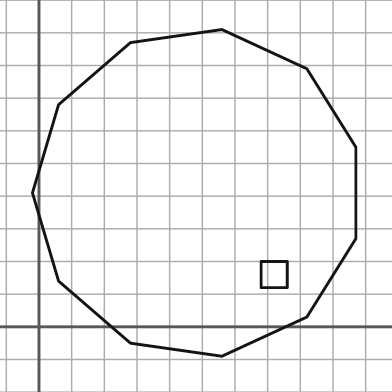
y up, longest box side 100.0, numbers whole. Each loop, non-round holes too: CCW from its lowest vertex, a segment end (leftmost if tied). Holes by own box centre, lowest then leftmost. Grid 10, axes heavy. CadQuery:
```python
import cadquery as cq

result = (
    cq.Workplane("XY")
    .moveTo(56.0, -9.0)
    .lineTo(82.0, 3.0)
    .lineTo(97.0, 27.0)
    .lineTo(97.0, 55.0)
    .lineTo(82.0, 79.0)
    .lineTo(56.0, 91.0)
    .lineTo(28.0, 87.0)
    .lineTo(6.0, 68.0)
    .lineTo(-2.0, 41.0)
    .lineTo(6.0, 14.0)
    .lineTo(28.0, -5.0)
    .close()
    .moveTo(68.0, 12.0)
    .lineTo(76.0, 12.0)
    .lineTo(76.0, 20.0)
    .lineTo(68.0, 20.0)
    .close()
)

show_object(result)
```